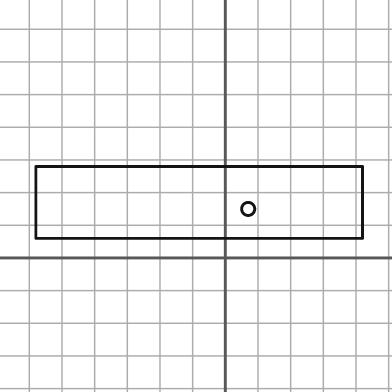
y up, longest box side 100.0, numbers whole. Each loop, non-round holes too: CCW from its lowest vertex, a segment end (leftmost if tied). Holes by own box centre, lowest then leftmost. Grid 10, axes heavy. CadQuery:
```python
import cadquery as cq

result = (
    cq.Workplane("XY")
    .moveTo(-58.0, 6.0)
    .lineTo(42.0, 6.0)
    .lineTo(42.0, 28.0)
    .lineTo(-58.0, 28.0)
    .close()
    .moveTo(7.0, 15.0)
    .circle(2.0)
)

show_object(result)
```